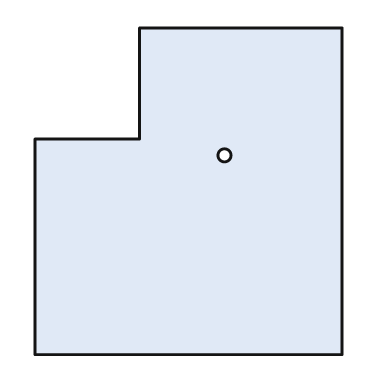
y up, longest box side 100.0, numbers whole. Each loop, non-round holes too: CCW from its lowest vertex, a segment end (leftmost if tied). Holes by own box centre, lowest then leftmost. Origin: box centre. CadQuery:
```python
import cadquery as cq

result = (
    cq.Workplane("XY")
    .moveTo(-47.0, -50.0)
    .lineTo(47.0, -50.0)
    .lineTo(47.0, 50.0)
    .lineTo(-15.0, 50.0)
    .lineTo(-15.0, 16.0)
    .lineTo(-47.0, 16.0)
    .close()
    .moveTo(11.0, 11.0)
    .circle(2.0)
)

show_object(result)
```